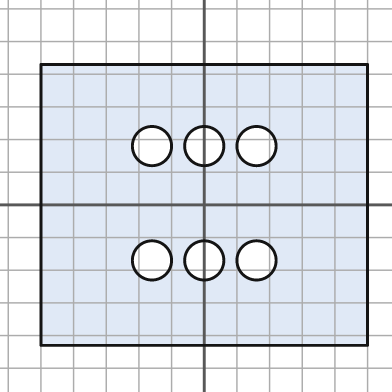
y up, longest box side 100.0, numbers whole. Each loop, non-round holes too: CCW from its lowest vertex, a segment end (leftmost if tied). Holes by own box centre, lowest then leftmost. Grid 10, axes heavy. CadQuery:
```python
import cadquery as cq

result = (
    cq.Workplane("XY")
    .moveTo(-50.0, -43.0)
    .lineTo(50.0, -43.0)
    .lineTo(50.0, 43.0)
    .lineTo(-50.0, 43.0)
    .close()
    .moveTo(-16.0, -17.0)
    .circle(6.0)
    .moveTo(0.0, -17.0)
    .circle(6.0)
    .moveTo(16.0, -17.0)
    .circle(6.0)
    .moveTo(-16.0, 18.0)
    .circle(6.0)
    .moveTo(0.0, 18.0)
    .circle(6.0)
    .moveTo(16.0, 18.0)
    .circle(6.0)
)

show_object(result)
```